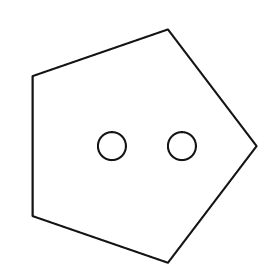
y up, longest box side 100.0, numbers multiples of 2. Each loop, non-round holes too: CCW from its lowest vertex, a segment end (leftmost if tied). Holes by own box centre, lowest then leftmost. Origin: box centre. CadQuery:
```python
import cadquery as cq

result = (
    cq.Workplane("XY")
    .moveTo(10.0, -50.0)
    .lineTo(48.0, 0.0)
    .lineTo(10.0, 50.0)
    .lineTo(-48.0, 30.0)
    .lineTo(-48.0, -30.0)
    .close()
    .moveTo(-14.0, 0.0)
    .circle(6.0)
    .moveTo(16.0, 0.0)
    .circle(6.0)
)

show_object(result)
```